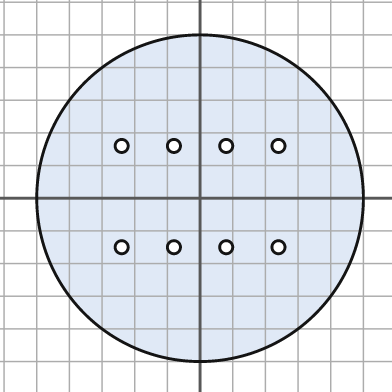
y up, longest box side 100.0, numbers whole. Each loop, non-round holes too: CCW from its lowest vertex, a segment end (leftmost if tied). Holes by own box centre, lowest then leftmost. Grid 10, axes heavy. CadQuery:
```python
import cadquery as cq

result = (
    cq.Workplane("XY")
    .moveTo(0.0, 0.0)
    .circle(50.0)
    .moveTo(-24.0, -15.0)
    .circle(2.0)
    .moveTo(-8.0, -15.0)
    .circle(2.0)
    .moveTo(8.0, -15.0)
    .circle(2.0)
    .moveTo(24.0, -15.0)
    .circle(2.0)
    .moveTo(-24.0, 16.0)
    .circle(2.0)
    .moveTo(-8.0, 16.0)
    .circle(2.0)
    .moveTo(8.0, 16.0)
    .circle(2.0)
    .moveTo(24.0, 16.0)
    .circle(2.0)
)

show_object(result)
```